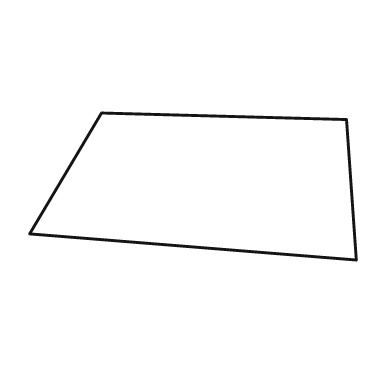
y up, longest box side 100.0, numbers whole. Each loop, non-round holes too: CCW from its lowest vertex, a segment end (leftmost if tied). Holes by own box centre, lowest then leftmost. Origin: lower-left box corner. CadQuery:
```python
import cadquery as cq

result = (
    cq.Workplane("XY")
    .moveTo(100.0, 0.0)
    .lineTo(97.0, 43.0)
    .lineTo(22.0, 45.0)
    .lineTo(0.0, 8.0)
    .close()
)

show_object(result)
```